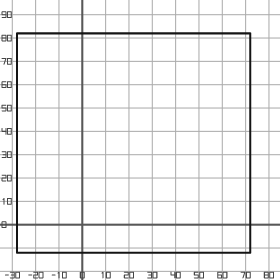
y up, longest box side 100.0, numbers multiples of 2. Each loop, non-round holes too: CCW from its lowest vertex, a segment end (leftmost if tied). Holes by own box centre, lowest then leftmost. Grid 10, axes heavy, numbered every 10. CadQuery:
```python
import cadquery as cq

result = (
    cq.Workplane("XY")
    .moveTo(-28.0, -12.0)
    .lineTo(72.0, -12.0)
    .lineTo(72.0, 82.0)
    .lineTo(-28.0, 82.0)
    .close()
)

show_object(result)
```